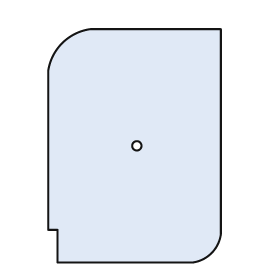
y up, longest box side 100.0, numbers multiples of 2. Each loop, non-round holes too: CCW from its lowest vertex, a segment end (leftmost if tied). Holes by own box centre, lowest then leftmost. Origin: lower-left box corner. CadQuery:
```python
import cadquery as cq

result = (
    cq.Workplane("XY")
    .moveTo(4.0, 0.0)
    .lineTo(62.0, 0.0)
    .threePointArc((70.0, 4.0), (74.0, 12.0))
    .lineTo(74.0, 100.0)
    .lineTo(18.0, 100.0)
    .threePointArc((6.0, 94.0), (0.0, 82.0))
    .lineTo(0.0, 14.0)
    .lineTo(4.0, 14.0)
    .close()
    .moveTo(38.0, 50.0)
    .circle(2.0)
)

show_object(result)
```